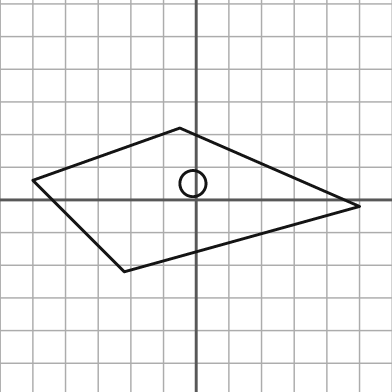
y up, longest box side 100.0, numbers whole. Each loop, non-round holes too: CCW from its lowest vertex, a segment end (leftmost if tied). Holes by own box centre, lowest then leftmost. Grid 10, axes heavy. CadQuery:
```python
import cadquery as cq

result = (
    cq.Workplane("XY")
    .moveTo(-22.0, -22.0)
    .lineTo(50.0, -2.0)
    .lineTo(-5.0, 22.0)
    .lineTo(-50.0, 6.0)
    .close()
    .moveTo(-1.0, 5.0)
    .circle(4.0)
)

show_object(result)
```